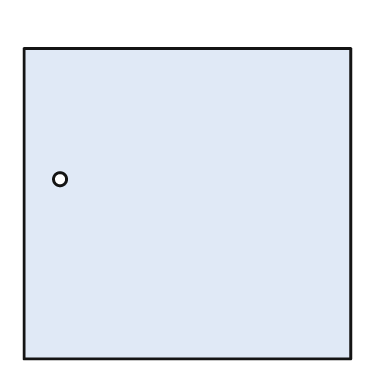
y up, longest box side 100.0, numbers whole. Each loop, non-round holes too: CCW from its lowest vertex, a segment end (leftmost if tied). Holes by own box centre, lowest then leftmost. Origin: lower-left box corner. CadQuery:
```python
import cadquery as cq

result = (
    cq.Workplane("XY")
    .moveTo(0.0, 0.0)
    .lineTo(100.0, 0.0)
    .lineTo(100.0, 95.0)
    .lineTo(0.0, 95.0)
    .close()
    .moveTo(11.0, 55.0)
    .circle(2.0)
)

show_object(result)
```